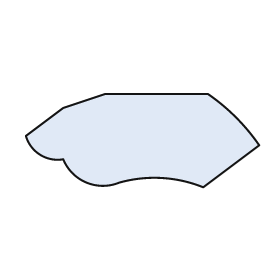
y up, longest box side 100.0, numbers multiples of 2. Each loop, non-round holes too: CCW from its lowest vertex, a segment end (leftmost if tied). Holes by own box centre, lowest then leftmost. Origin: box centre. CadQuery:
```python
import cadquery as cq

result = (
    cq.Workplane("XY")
    .moveTo(26.0, -20.0)
    .lineTo(50.0, -2.0)
    .threePointArc((40.0, 10.0), (28.0, 20.0))
    .lineTo(-16.0, 20.0)
    .lineTo(-34.0, 14.0)
    .lineTo(-50.0, 2.0)
    .threePointArc((-44.0, -6.0), (-34.0, -8.0))
    .threePointArc((-24.0, -18.0), (-10.0, -18.0))
    .threePointArc((8.0, -16.0), (26.0, -20.0))
    .close()
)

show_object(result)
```